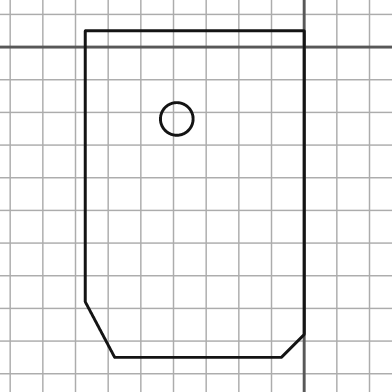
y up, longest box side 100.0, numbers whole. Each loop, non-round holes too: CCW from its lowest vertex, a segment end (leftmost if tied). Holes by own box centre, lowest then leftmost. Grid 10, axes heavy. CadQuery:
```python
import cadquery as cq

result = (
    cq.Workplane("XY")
    .moveTo(-58.0, -95.0)
    .lineTo(-7.0, -95.0)
    .lineTo(0.0, -88.0)
    .lineTo(0.0, 5.0)
    .lineTo(-67.0, 5.0)
    .lineTo(-67.0, -78.0)
    .close()
    .moveTo(-39.0, -22.0)
    .circle(5.0)
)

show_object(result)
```